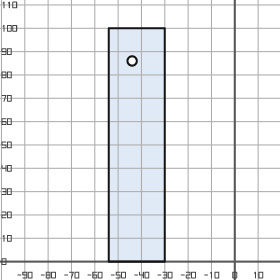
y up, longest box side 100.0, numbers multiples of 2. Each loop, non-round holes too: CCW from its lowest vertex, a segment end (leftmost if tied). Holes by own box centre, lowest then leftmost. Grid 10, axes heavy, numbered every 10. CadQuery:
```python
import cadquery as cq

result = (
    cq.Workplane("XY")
    .moveTo(-54.0, 0.0)
    .lineTo(-30.0, 0.0)
    .lineTo(-30.0, 100.0)
    .lineTo(-54.0, 100.0)
    .close()
    .moveTo(-44.0, 86.0)
    .circle(2.0)
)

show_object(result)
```